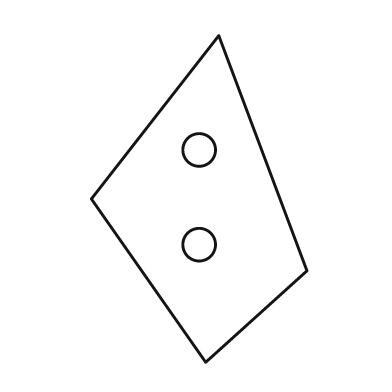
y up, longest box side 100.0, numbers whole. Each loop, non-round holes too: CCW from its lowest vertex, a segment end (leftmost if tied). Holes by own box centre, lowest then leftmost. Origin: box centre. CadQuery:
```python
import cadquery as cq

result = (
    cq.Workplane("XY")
    .moveTo(2.0, -50.0)
    .lineTo(33.0, -22.0)
    .lineTo(6.0, 50.0)
    .lineTo(-33.0, 0.0)
    .close()
    .moveTo(0.0, -14.0)
    .circle(5.0)
    .moveTo(0.0, 15.0)
    .circle(5.0)
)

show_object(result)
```